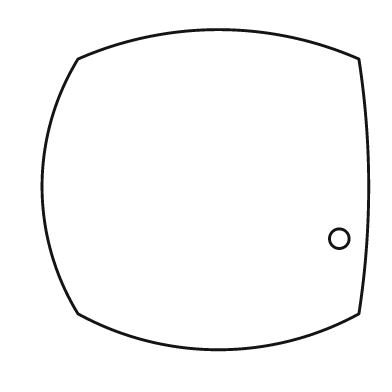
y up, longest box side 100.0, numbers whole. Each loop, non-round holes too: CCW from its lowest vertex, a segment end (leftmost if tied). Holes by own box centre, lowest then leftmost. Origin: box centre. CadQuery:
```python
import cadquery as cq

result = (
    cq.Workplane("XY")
    .moveTo(-39.0, -38.0)
    .threePointArc((4.0, -49.0), (47.0, -38.0))
    .threePointArc((50.0, 1.0), (47.0, 40.0))
    .threePointArc((4.0, 49.0), (-39.0, 40.0))
    .threePointArc((-50.0, 1.0), (-39.0, -38.0))
    .close()
    .moveTo(41.0, -15.0)
    .circle(3.0)
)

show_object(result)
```